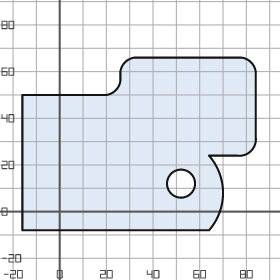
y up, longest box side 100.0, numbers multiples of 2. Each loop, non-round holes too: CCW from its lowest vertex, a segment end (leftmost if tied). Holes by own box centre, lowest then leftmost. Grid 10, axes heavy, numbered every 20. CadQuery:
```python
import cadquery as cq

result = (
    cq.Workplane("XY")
    .moveTo(-16.0, -8.0)
    .lineTo(64.0, -8.0)
    .threePointArc((70.0, 8.0), (64.0, 24.0))
    .lineTo(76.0, 24.0)
    .threePointArc((82.0, 26.0), (84.0, 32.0))
    .lineTo(84.0, 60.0)
    .threePointArc((82.0, 64.0), (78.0, 66.0))
    .lineTo(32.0, 66.0)
    .threePointArc((28.0, 64.0), (26.0, 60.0))
    .lineTo(26.0, 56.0)
    .threePointArc((24.0, 52.0), (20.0, 50.0))
    .lineTo(-16.0, 50.0)
    .close()
    .moveTo(52.0, 12.0)
    .circle(6.0)
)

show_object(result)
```